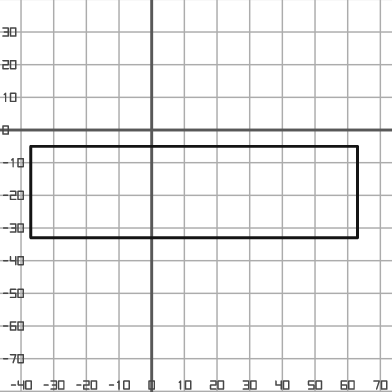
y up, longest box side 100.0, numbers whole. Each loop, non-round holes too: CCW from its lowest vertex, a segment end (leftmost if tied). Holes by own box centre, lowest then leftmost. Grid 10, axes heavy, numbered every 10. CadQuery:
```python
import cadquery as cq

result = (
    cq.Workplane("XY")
    .moveTo(-37.0, -33.0)
    .lineTo(63.0, -33.0)
    .lineTo(63.0, -5.0)
    .lineTo(-37.0, -5.0)
    .close()
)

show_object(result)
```